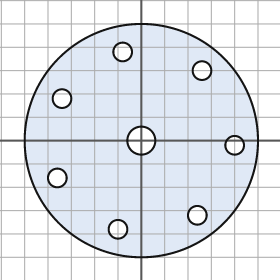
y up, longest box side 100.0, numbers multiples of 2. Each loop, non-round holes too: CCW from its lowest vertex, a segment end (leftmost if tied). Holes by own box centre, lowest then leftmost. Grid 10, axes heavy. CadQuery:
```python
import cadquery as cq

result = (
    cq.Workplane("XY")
    .moveTo(0.0, 0.0)
    .circle(50.0)
    .moveTo(-10.0, -38.0)
    .circle(4.0)
    .moveTo(24.0, -32.0)
    .circle(4.0)
    .moveTo(-36.0, -16.0)
    .circle(4.0)
    .moveTo(40.0, -2.0)
    .circle(4.0)
    .moveTo(0.0, 0.0)
    .circle(6.0)
    .moveTo(-34.0, 18.0)
    .circle(4.0)
    .moveTo(26.0, 30.0)
    .circle(4.0)
    .moveTo(-8.0, 38.0)
    .circle(4.0)
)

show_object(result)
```